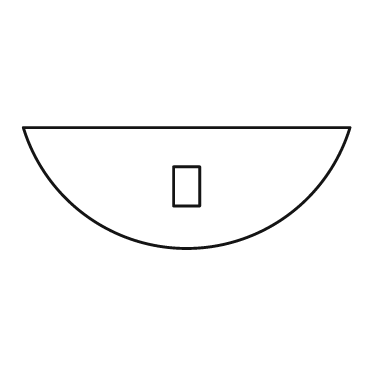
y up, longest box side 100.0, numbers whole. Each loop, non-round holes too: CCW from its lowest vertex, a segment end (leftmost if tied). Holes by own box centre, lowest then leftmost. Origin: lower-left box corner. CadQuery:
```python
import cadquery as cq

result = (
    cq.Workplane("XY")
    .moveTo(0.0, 37.0)
    .threePointArc((50.0, 0.0), (100.0, 37.0))
    .close()
    .moveTo(46.0, 13.0)
    .lineTo(54.0, 13.0)
    .lineTo(54.0, 25.0)
    .lineTo(46.0, 25.0)
    .close()
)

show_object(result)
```